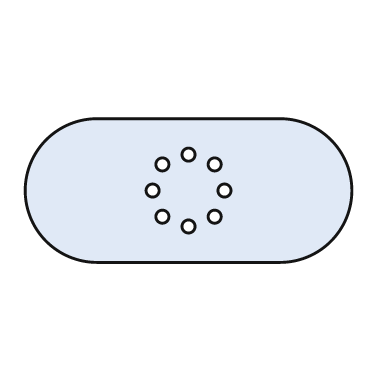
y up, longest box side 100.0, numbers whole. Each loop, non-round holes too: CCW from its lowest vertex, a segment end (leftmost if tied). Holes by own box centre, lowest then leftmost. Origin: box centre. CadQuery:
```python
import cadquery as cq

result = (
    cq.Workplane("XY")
    .moveTo(-28.0, -22.0)
    .lineTo(28.0, -22.0)
    .threePointArc((50.0, 0.0), (28.0, 22.0))
    .lineTo(-28.0, 22.0)
    .threePointArc((-50.0, 0.0), (-28.0, -22.0))
    .close()
    .moveTo(0.0, -11.0)
    .circle(2.0)
    .moveTo(-8.0, -8.0)
    .circle(2.0)
    .moveTo(8.0, -8.0)
    .circle(2.0)
    .moveTo(-11.0, 0.0)
    .circle(2.0)
    .moveTo(11.0, 0.0)
    .circle(2.0)
    .moveTo(-8.0, 8.0)
    .circle(2.0)
    .moveTo(8.0, 8.0)
    .circle(2.0)
    .moveTo(0.0, 11.0)
    .circle(2.0)
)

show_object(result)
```